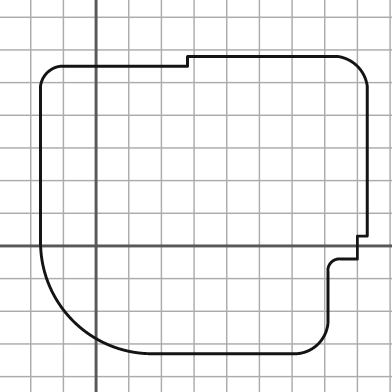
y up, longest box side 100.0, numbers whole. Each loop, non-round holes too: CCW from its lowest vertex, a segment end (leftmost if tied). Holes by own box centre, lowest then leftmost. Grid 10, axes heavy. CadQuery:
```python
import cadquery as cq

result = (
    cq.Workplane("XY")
    .moveTo(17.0, -33.0)
    .lineTo(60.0, -33.0)
    .threePointArc((68.0, -30.0), (71.0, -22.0))
    .lineTo(71.0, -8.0)
    .threePointArc((72.0, -5.0), (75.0, -4.0))
    .lineTo(80.0, -4.0)
    .lineTo(80.0, 3.0)
    .lineTo(83.0, 3.0)
    .lineTo(83.0, 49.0)
    .threePointArc((80.0, 55.0), (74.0, 58.0))
    .lineTo(28.0, 58.0)
    .lineTo(28.0, 55.0)
    .lineTo(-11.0, 55.0)
    .threePointArc((-15.0, 53.0), (-17.0, 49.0))
    .lineTo(-17.0, 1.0)
    .threePointArc((-7.0, -23.0), (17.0, -33.0))
    .close()
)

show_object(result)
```